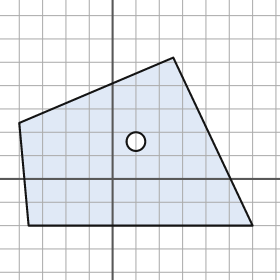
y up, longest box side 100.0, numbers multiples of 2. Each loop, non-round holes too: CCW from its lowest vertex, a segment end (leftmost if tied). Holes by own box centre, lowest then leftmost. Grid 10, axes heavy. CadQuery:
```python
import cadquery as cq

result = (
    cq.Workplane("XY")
    .moveTo(-36.0, -20.0)
    .lineTo(60.0, -20.0)
    .lineTo(26.0, 52.0)
    .lineTo(-40.0, 24.0)
    .close()
    .moveTo(10.0, 16.0)
    .circle(4.0)
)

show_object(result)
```